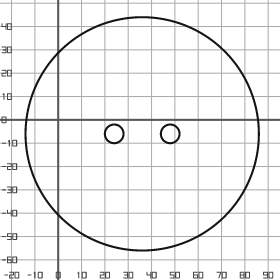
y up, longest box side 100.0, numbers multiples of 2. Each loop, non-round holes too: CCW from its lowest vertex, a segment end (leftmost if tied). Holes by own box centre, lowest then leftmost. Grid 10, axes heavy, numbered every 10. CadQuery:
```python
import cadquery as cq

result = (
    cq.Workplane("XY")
    .moveTo(36.0, -6.0)
    .circle(50.0)
    .moveTo(24.0, -6.0)
    .circle(4.0)
    .moveTo(48.0, -6.0)
    .circle(4.0)
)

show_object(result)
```